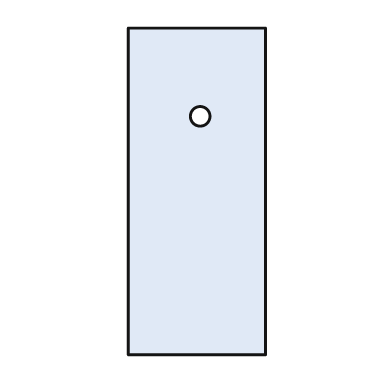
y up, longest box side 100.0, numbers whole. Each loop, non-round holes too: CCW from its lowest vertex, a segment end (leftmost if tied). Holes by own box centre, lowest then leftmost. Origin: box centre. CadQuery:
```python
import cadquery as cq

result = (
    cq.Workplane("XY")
    .moveTo(-21.0, -50.0)
    .lineTo(21.0, -50.0)
    .lineTo(21.0, 50.0)
    .lineTo(-21.0, 50.0)
    .close()
    .moveTo(1.0, 23.0)
    .circle(3.0)
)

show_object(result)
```